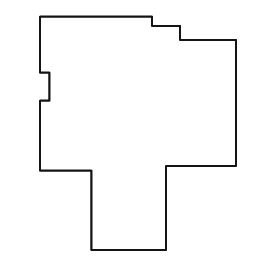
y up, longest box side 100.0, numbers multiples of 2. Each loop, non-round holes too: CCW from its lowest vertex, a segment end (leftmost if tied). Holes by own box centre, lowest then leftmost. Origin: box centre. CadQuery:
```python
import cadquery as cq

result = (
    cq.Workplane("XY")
    .moveTo(-20.0, -50.0)
    .lineTo(12.0, -50.0)
    .lineTo(12.0, -14.0)
    .lineTo(42.0, -14.0)
    .lineTo(42.0, 40.0)
    .lineTo(18.0, 40.0)
    .lineTo(18.0, 46.0)
    .lineTo(6.0, 46.0)
    .lineTo(6.0, 50.0)
    .lineTo(-42.0, 50.0)
    .lineTo(-42.0, 26.0)
    .lineTo(-38.0, 26.0)
    .lineTo(-38.0, 14.0)
    .lineTo(-42.0, 14.0)
    .lineTo(-42.0, -16.0)
    .lineTo(-20.0, -16.0)
    .close()
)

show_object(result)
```